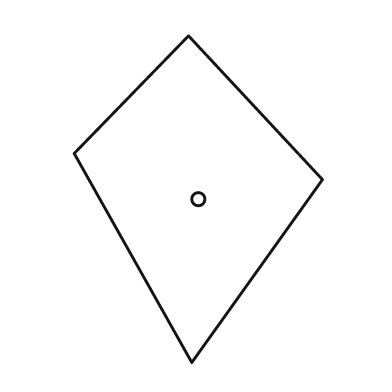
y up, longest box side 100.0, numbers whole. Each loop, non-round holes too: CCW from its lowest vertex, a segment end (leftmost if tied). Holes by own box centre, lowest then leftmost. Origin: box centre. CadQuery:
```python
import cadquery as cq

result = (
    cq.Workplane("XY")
    .moveTo(-2.0, -50.0)
    .lineTo(38.0, 6.0)
    .lineTo(-3.0, 50.0)
    .lineTo(-38.0, 14.0)
    .close()
    .moveTo(0.0, 0.0)
    .circle(2.0)
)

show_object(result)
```